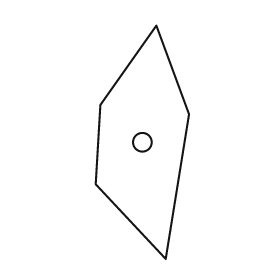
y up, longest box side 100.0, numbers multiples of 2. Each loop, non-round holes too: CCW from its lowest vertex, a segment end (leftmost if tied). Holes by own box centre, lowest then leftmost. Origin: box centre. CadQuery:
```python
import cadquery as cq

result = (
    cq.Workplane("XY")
    .moveTo(10.0, -50.0)
    .lineTo(20.0, 12.0)
    .lineTo(6.0, 50.0)
    .lineTo(-18.0, 16.0)
    .lineTo(-20.0, -18.0)
    .close()
    .moveTo(0.0, 0.0)
    .circle(4.0)
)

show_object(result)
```